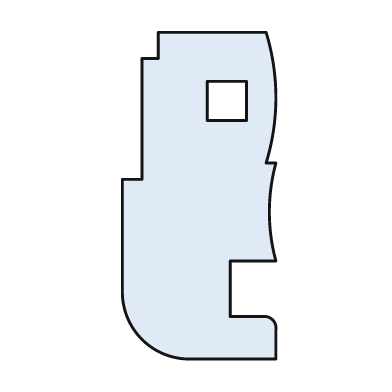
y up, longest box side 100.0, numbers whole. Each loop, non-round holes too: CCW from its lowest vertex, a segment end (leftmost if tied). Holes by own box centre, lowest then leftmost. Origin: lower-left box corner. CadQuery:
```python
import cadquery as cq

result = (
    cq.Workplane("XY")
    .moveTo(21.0, 0.0)
    .lineTo(47.0, 0.0)
    .lineTo(47.0, 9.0)
    .threePointArc((46.0, 12.0), (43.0, 13.0))
    .lineTo(33.0, 13.0)
    .lineTo(33.0, 30.0)
    .lineTo(47.0, 30.0)
    .threePointArc((45.0, 45.0), (47.0, 60.0))
    .lineTo(44.0, 60.0)
    .threePointArc((47.0, 80.0), (44.0, 100.0))
    .lineTo(11.0, 100.0)
    .lineTo(11.0, 92.0)
    .lineTo(6.0, 92.0)
    .lineTo(6.0, 55.0)
    .lineTo(0.0, 55.0)
    .lineTo(0.0, 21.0)
    .threePointArc((6.0, 6.0), (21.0, 0.0))
    .close()
    .moveTo(26.0, 73.0)
    .lineTo(38.0, 73.0)
    .lineTo(38.0, 85.0)
    .lineTo(26.0, 85.0)
    .close()
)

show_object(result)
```